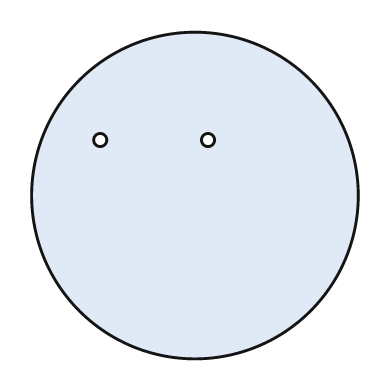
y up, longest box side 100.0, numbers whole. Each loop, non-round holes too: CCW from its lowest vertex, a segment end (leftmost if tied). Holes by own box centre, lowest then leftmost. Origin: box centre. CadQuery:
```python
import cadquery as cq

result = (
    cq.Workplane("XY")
    .moveTo(0.0, 0.0)
    .circle(50.0)
    .moveTo(-29.0, 17.0)
    .circle(2.0)
    .moveTo(4.0, 17.0)
    .circle(2.0)
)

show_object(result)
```